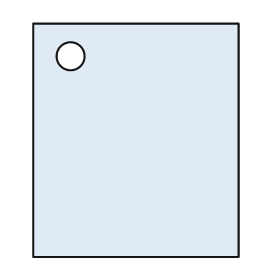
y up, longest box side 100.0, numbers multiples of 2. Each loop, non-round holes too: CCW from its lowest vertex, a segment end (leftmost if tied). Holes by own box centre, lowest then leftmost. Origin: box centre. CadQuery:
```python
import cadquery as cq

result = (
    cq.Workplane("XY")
    .moveTo(-44.0, -50.0)
    .lineTo(44.0, -50.0)
    .lineTo(44.0, 50.0)
    .lineTo(-44.0, 50.0)
    .close()
    .moveTo(-28.0, 36.0)
    .circle(6.0)
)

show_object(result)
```